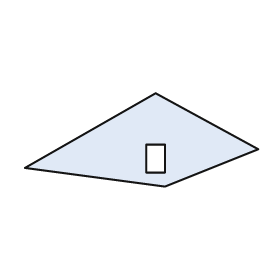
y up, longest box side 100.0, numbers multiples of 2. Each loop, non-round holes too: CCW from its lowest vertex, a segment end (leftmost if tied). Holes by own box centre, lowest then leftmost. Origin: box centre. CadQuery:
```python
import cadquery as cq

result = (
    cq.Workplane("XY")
    .moveTo(10.0, -20.0)
    .lineTo(50.0, -4.0)
    .lineTo(6.0, 20.0)
    .lineTo(-50.0, -12.0)
    .close()
    .moveTo(2.0, -14.0)
    .lineTo(10.0, -14.0)
    .lineTo(10.0, -2.0)
    .lineTo(2.0, -2.0)
    .close()
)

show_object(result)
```